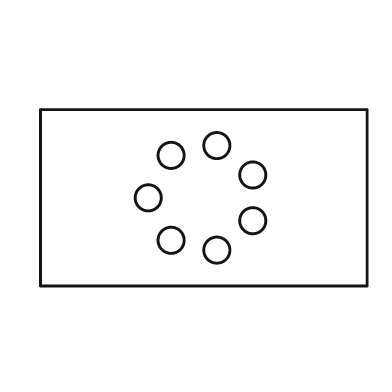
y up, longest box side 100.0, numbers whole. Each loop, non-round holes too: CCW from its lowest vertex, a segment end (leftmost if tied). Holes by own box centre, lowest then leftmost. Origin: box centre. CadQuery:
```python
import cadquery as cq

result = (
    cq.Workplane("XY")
    .moveTo(-50.0, -27.0)
    .lineTo(50.0, -27.0)
    .lineTo(50.0, 27.0)
    .lineTo(-50.0, 27.0)
    .close()
    .moveTo(4.0, -16.0)
    .circle(4.0)
    .moveTo(-10.0, -13.0)
    .circle(4.0)
    .moveTo(15.0, -7.0)
    .circle(4.0)
    .moveTo(-17.0, 0.0)
    .circle(4.0)
    .moveTo(15.0, 7.0)
    .circle(4.0)
    .moveTo(-10.0, 13.0)
    .circle(4.0)
    .moveTo(4.0, 16.0)
    .circle(4.0)
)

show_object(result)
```